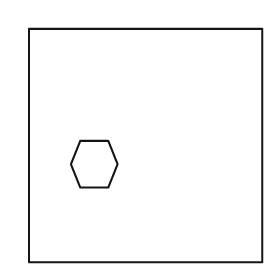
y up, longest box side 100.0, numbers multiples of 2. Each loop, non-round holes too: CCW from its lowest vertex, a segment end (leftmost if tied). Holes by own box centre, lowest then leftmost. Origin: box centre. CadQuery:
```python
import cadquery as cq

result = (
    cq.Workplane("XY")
    .moveTo(-50.0, -50.0)
    .lineTo(50.0, -50.0)
    .lineTo(50.0, 50.0)
    .lineTo(-50.0, 50.0)
    .close()
    .moveTo(-28.0, -18.0)
    .lineTo(-16.0, -18.0)
    .lineTo(-12.0, -8.0)
    .lineTo(-16.0, 2.0)
    .lineTo(-28.0, 2.0)
    .lineTo(-32.0, -8.0)
    .close()
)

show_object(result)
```